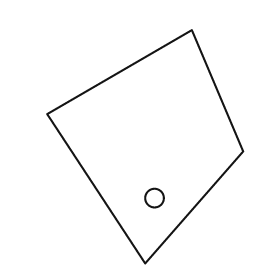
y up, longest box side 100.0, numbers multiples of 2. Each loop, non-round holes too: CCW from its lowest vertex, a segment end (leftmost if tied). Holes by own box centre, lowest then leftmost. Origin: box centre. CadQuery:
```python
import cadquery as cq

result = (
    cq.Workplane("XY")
    .moveTo(0.0, -50.0)
    .lineTo(42.0, -2.0)
    .lineTo(20.0, 50.0)
    .lineTo(-42.0, 14.0)
    .close()
    .moveTo(4.0, -22.0)
    .circle(4.0)
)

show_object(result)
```